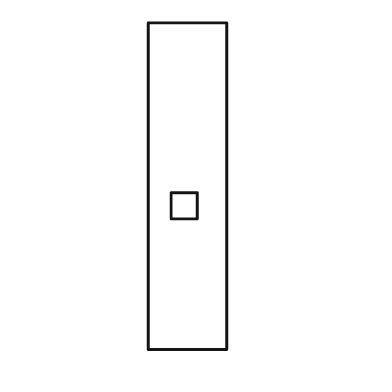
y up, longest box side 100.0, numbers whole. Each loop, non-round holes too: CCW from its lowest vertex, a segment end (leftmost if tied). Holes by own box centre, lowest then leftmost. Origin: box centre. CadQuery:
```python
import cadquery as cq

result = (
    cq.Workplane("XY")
    .moveTo(-12.0, -50.0)
    .lineTo(12.0, -50.0)
    .lineTo(12.0, 50.0)
    .lineTo(-12.0, 50.0)
    .close()
    .moveTo(-5.0, -10.0)
    .lineTo(3.0, -10.0)
    .lineTo(3.0, -2.0)
    .lineTo(-5.0, -2.0)
    .close()
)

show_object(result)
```